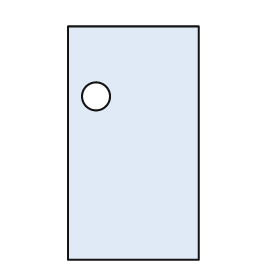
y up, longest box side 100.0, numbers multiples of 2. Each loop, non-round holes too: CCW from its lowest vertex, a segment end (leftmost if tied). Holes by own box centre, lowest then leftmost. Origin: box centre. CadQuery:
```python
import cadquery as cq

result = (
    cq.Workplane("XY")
    .moveTo(-28.0, -50.0)
    .lineTo(28.0, -50.0)
    .lineTo(28.0, 50.0)
    .lineTo(-28.0, 50.0)
    .close()
    .moveTo(-16.0, 20.0)
    .circle(6.0)
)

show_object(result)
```